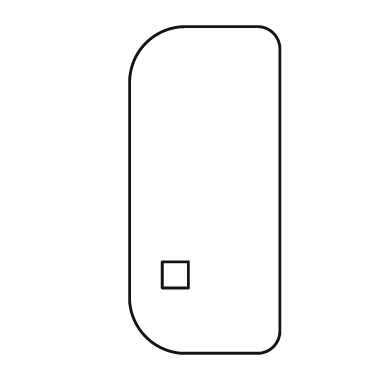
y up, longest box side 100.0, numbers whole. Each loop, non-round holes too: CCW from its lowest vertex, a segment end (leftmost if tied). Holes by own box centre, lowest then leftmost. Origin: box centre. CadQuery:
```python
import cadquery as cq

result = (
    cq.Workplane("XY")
    .moveTo(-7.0, -50.0)
    .lineTo(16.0, -50.0)
    .threePointArc((21.0, -48.0), (23.0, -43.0))
    .lineTo(23.0, 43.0)
    .threePointArc((21.0, 48.0), (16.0, 50.0))
    .lineTo(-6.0, 50.0)
    .threePointArc((-18.0, 45.0), (-23.0, 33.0))
    .lineTo(-23.0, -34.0)
    .threePointArc((-18.0, -45.0), (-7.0, -50.0))
    .close()
    .moveTo(-13.0, -30.0)
    .lineTo(-5.0, -30.0)
    .lineTo(-5.0, -22.0)
    .lineTo(-13.0, -22.0)
    .close()
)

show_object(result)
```